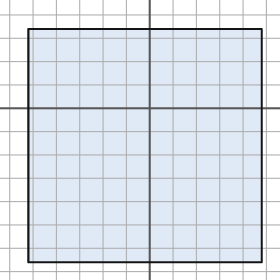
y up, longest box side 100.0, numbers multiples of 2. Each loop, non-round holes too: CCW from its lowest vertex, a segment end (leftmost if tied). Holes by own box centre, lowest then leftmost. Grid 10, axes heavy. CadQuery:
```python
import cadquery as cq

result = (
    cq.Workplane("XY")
    .moveTo(-52.0, -66.0)
    .lineTo(48.0, -66.0)
    .lineTo(48.0, 34.0)
    .lineTo(-52.0, 34.0)
    .close()
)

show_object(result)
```